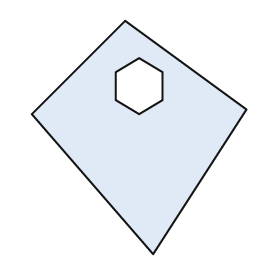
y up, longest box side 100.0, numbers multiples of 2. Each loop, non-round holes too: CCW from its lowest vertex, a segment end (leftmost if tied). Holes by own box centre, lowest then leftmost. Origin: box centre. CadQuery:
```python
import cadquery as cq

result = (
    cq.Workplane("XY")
    .moveTo(6.0, -50.0)
    .lineTo(46.0, 12.0)
    .lineTo(-6.0, 50.0)
    .lineTo(-46.0, 10.0)
    .close()
    .moveTo(0.0, 10.0)
    .lineTo(10.0, 16.0)
    .lineTo(10.0, 28.0)
    .lineTo(0.0, 34.0)
    .lineTo(-10.0, 28.0)
    .lineTo(-10.0, 16.0)
    .close()
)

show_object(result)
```